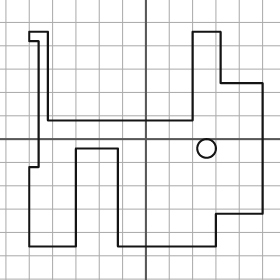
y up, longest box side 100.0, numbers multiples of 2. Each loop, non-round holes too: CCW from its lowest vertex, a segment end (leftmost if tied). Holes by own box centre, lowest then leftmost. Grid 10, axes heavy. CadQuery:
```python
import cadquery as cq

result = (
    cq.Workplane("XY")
    .moveTo(-50.0, -46.0)
    .lineTo(-30.0, -46.0)
    .lineTo(-30.0, -4.0)
    .lineTo(-12.0, -4.0)
    .lineTo(-12.0, -46.0)
    .lineTo(30.0, -46.0)
    .lineTo(30.0, -32.0)
    .lineTo(50.0, -32.0)
    .lineTo(50.0, 24.0)
    .lineTo(32.0, 24.0)
    .lineTo(32.0, 46.0)
    .lineTo(20.0, 46.0)
    .lineTo(20.0, 8.0)
    .lineTo(-42.0, 8.0)
    .lineTo(-42.0, 46.0)
    .lineTo(-50.0, 46.0)
    .lineTo(-50.0, 42.0)
    .lineTo(-46.0, 42.0)
    .lineTo(-46.0, -12.0)
    .lineTo(-50.0, -12.0)
    .close()
    .moveTo(26.0, -4.0)
    .circle(4.0)
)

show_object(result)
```